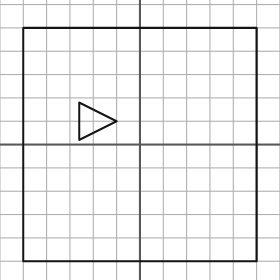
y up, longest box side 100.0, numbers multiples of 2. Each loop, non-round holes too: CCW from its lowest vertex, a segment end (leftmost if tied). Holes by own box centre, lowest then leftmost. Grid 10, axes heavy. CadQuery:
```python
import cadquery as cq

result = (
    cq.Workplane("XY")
    .moveTo(-50.0, -50.0)
    .lineTo(50.0, -50.0)
    .lineTo(50.0, 50.0)
    .lineTo(-50.0, 50.0)
    .close()
    .moveTo(-26.0, 2.0)
    .lineTo(-10.0, 10.0)
    .lineTo(-26.0, 18.0)
    .close()
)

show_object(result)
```